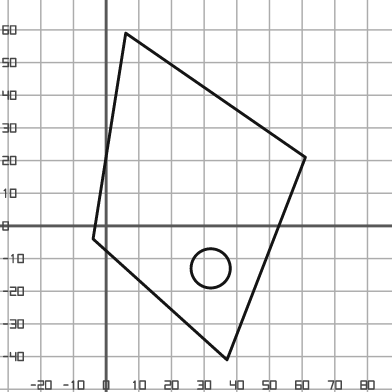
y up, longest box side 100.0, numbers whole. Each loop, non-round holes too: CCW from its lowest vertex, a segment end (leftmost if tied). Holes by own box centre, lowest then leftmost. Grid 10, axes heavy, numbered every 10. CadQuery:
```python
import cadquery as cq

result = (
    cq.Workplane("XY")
    .moveTo(37.0, -41.0)
    .lineTo(61.0, 21.0)
    .lineTo(6.0, 59.0)
    .lineTo(-4.0, -4.0)
    .close()
    .moveTo(32.0, -13.0)
    .circle(6.0)
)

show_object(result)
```